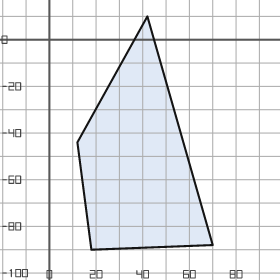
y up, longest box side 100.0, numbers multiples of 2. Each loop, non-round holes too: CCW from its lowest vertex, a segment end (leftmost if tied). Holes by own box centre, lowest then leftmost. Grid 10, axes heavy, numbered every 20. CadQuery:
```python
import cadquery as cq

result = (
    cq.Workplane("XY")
    .moveTo(18.0, -90.0)
    .lineTo(70.0, -88.0)
    .lineTo(42.0, 10.0)
    .lineTo(12.0, -44.0)
    .close()
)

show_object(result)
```